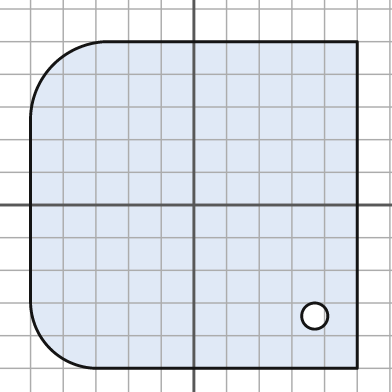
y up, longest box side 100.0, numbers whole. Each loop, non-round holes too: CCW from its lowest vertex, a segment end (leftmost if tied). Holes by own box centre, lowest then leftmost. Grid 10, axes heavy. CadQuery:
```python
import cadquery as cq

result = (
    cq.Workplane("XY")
    .moveTo(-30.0, -50.0)
    .lineTo(50.0, -50.0)
    .lineTo(50.0, 50.0)
    .lineTo(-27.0, 50.0)
    .threePointArc((-43.0, 43.0), (-50.0, 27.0))
    .lineTo(-50.0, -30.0)
    .threePointArc((-44.0, -44.0), (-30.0, -50.0))
    .close()
    .moveTo(37.0, -34.0)
    .circle(4.0)
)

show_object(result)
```